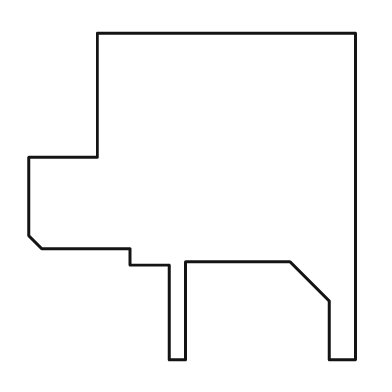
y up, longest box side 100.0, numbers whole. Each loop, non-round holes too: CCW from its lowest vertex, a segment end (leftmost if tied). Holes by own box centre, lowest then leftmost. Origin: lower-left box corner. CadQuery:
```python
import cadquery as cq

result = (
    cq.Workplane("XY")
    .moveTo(43.0, 0.0)
    .lineTo(48.0, 0.0)
    .lineTo(48.0, 30.0)
    .lineTo(80.0, 30.0)
    .lineTo(92.0, 18.0)
    .lineTo(92.0, 0.0)
    .lineTo(100.0, 0.0)
    .lineTo(100.0, 100.0)
    .lineTo(21.0, 100.0)
    .lineTo(21.0, 62.0)
    .lineTo(0.0, 62.0)
    .lineTo(0.0, 38.0)
    .lineTo(4.0, 34.0)
    .lineTo(31.0, 34.0)
    .lineTo(31.0, 29.0)
    .lineTo(43.0, 29.0)
    .close()
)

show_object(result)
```